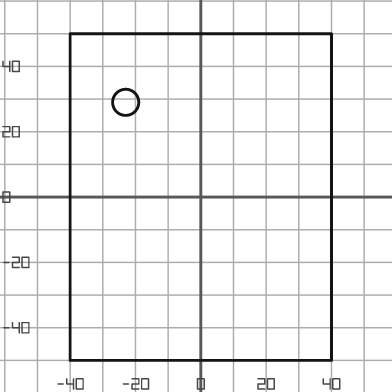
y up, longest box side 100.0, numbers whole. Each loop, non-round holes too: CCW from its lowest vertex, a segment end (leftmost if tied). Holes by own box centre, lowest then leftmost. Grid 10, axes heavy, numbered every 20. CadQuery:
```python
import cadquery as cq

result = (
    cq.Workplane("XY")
    .moveTo(-40.0, -50.0)
    .lineTo(40.0, -50.0)
    .lineTo(40.0, 50.0)
    .lineTo(-40.0, 50.0)
    .close()
    .moveTo(-23.0, 29.0)
    .circle(4.0)
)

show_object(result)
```